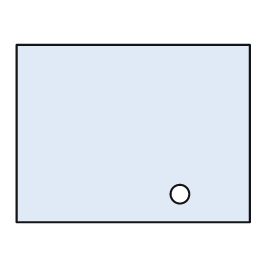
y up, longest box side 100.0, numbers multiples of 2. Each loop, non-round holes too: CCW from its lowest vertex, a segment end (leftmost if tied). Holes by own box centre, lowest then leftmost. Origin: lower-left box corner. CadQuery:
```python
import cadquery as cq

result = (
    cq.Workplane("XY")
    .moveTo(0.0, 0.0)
    .lineTo(100.0, 0.0)
    .lineTo(100.0, 76.0)
    .lineTo(0.0, 76.0)
    .close()
    .moveTo(70.0, 12.0)
    .circle(4.0)
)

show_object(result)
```